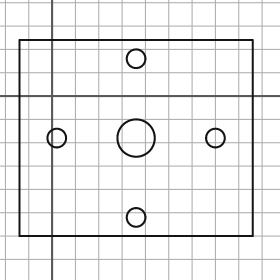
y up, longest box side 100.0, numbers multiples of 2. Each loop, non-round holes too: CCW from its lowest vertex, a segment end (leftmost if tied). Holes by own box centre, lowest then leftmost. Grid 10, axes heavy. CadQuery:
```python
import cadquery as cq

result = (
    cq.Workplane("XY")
    .moveTo(-14.0, -60.0)
    .lineTo(86.0, -60.0)
    .lineTo(86.0, 24.0)
    .lineTo(-14.0, 24.0)
    .close()
    .moveTo(36.0, -52.0)
    .circle(4.0)
    .moveTo(2.0, -18.0)
    .circle(4.0)
    .moveTo(36.0, -18.0)
    .circle(8.0)
    .moveTo(70.0, -18.0)
    .circle(4.0)
    .moveTo(36.0, 16.0)
    .circle(4.0)
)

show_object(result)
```